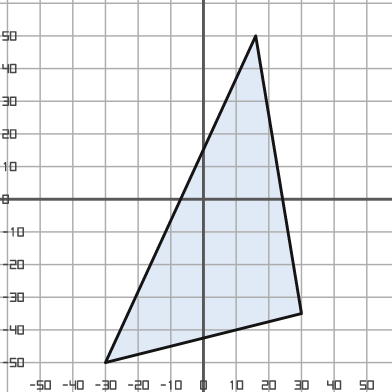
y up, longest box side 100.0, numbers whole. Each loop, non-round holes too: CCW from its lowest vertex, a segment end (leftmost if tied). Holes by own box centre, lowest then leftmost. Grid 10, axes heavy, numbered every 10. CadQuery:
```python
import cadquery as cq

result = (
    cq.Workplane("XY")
    .moveTo(-30.0, -50.0)
    .lineTo(30.0, -35.0)
    .lineTo(16.0, 50.0)
    .close()
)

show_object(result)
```